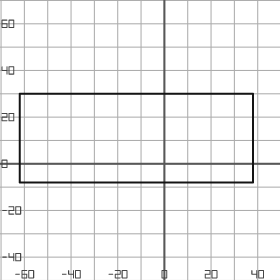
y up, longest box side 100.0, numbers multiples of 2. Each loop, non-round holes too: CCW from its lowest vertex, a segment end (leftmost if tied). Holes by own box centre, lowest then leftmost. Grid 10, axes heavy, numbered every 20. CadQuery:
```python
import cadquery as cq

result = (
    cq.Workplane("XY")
    .moveTo(-62.0, -8.0)
    .lineTo(38.0, -8.0)
    .lineTo(38.0, 30.0)
    .lineTo(-62.0, 30.0)
    .close()
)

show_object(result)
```